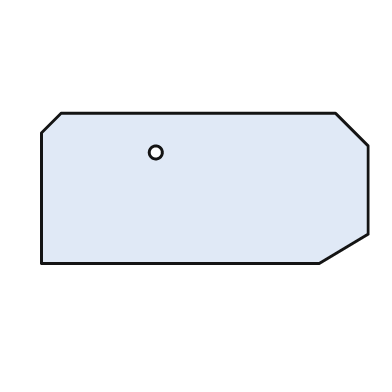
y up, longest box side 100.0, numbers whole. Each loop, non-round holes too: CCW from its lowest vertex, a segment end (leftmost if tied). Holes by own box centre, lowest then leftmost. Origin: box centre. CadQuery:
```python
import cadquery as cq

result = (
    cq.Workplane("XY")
    .moveTo(-50.0, -23.0)
    .lineTo(35.0, -23.0)
    .lineTo(50.0, -14.0)
    .lineTo(50.0, 13.0)
    .lineTo(40.0, 23.0)
    .lineTo(-44.0, 23.0)
    .lineTo(-50.0, 17.0)
    .close()
    .moveTo(-15.0, 11.0)
    .circle(2.0)
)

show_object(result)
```